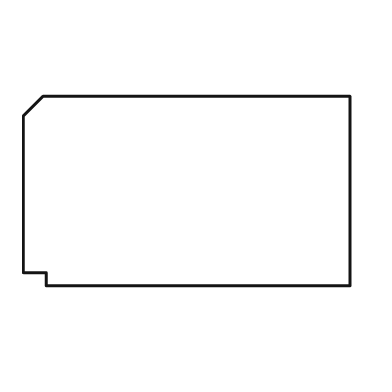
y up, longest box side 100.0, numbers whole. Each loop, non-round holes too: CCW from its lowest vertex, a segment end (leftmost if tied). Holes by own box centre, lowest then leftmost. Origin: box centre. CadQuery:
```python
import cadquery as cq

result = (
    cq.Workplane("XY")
    .moveTo(-43.0, -29.0)
    .lineTo(50.0, -29.0)
    .lineTo(50.0, 29.0)
    .lineTo(-44.0, 29.0)
    .lineTo(-50.0, 23.0)
    .lineTo(-50.0, -25.0)
    .lineTo(-43.0, -25.0)
    .close()
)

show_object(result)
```